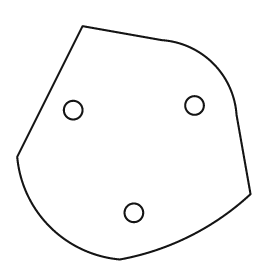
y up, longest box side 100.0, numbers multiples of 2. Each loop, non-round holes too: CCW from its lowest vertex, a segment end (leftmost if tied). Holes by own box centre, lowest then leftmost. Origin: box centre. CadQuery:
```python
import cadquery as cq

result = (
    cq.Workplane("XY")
    .moveTo(-6.0, -50.0)
    .threePointArc((24.0, -40.0), (50.0, -22.0))
    .lineTo(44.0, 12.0)
    .threePointArc((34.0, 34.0), (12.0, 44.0))
    .lineTo(-22.0, 50.0)
    .lineTo(-50.0, -6.0)
    .threePointArc((-36.0, -36.0), (-6.0, -50.0))
    .close()
    .moveTo(0.0, -30.0)
    .circle(4.0)
    .moveTo(-26.0, 14.0)
    .circle(4.0)
    .moveTo(26.0, 16.0)
    .circle(4.0)
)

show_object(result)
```